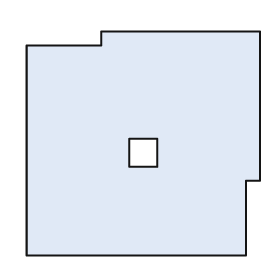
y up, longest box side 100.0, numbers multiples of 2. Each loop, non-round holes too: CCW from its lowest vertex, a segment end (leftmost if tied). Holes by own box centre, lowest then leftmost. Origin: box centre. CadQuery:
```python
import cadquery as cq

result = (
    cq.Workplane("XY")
    .moveTo(-50.0, -48.0)
    .lineTo(44.0, -48.0)
    .lineTo(44.0, -16.0)
    .lineTo(50.0, -16.0)
    .lineTo(50.0, 48.0)
    .lineTo(-18.0, 48.0)
    .lineTo(-18.0, 42.0)
    .lineTo(-50.0, 42.0)
    .close()
    .moveTo(-6.0, -10.0)
    .lineTo(6.0, -10.0)
    .lineTo(6.0, 2.0)
    .lineTo(-6.0, 2.0)
    .close()
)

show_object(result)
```